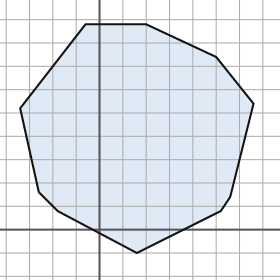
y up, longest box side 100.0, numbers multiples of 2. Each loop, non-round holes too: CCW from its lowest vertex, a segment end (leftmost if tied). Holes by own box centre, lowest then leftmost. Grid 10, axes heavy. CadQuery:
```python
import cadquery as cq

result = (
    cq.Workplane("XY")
    .moveTo(16.0, -10.0)
    .lineTo(52.0, 8.0)
    .lineTo(56.0, 14.0)
    .lineTo(66.0, 54.0)
    .lineTo(50.0, 74.0)
    .lineTo(20.0, 88.0)
    .lineTo(-6.0, 88.0)
    .lineTo(-34.0, 52.0)
    .lineTo(-26.0, 16.0)
    .lineTo(-18.0, 8.0)
    .close()
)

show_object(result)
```